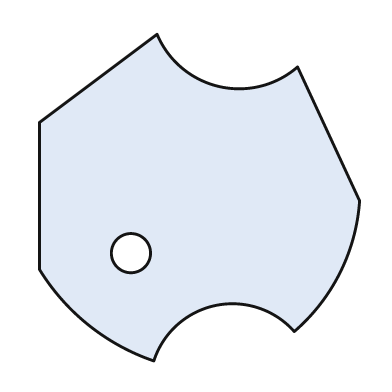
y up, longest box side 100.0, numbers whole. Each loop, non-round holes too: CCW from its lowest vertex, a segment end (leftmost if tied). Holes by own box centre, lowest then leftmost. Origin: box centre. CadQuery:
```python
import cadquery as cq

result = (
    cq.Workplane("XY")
    .moveTo(-14.0, -50.0)
    .threePointArc((5.0, -33.0), (29.0, -41.0))
    .threePointArc((43.0, -23.0), (49.0, -1.0))
    .lineTo(30.0, 40.0)
    .threePointArc((6.0, 34.0), (-13.0, 50.0))
    .lineTo(-49.0, 23.0)
    .lineTo(-49.0, -22.0)
    .threePointArc((-34.0, -39.0), (-14.0, -50.0))
    .close()
    .moveTo(-21.0, -17.0)
    .circle(6.0)
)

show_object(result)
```